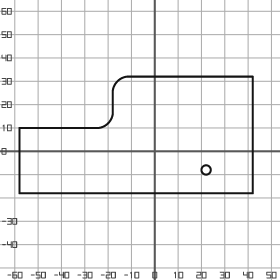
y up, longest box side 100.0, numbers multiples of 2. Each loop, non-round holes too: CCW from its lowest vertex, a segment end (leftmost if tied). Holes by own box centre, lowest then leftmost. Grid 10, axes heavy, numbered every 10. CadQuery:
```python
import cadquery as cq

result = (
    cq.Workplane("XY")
    .moveTo(-58.0, -18.0)
    .lineTo(42.0, -18.0)
    .lineTo(42.0, 32.0)
    .lineTo(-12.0, 32.0)
    .threePointArc((-16.0, 30.0), (-18.0, 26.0))
    .lineTo(-18.0, 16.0)
    .threePointArc((-20.0, 12.0), (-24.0, 10.0))
    .lineTo(-58.0, 10.0)
    .close()
    .moveTo(22.0, -8.0)
    .circle(2.0)
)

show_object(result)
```